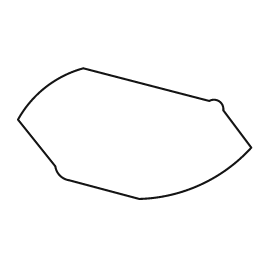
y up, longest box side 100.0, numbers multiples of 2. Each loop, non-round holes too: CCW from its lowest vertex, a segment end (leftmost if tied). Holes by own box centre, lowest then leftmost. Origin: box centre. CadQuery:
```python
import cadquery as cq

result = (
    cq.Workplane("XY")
    .moveTo(2.0, -28.0)
    .threePointArc((28.0, -22.0), (50.0, -6.0))
    .lineTo(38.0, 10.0)
    .threePointArc((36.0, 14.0), (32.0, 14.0))
    .lineTo(-22.0, 28.0)
    .threePointArc((-38.0, 20.0), (-50.0, 6.0))
    .lineTo(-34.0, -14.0)
    .threePointArc((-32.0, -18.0), (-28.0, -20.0))
    .close()
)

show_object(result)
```